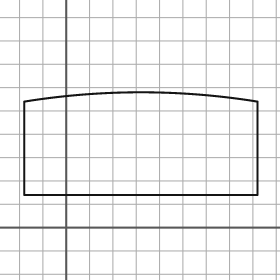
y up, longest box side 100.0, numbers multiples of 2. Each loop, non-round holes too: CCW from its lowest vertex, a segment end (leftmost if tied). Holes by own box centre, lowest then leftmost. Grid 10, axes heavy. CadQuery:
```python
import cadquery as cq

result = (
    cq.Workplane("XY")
    .moveTo(-18.0, 14.0)
    .lineTo(82.0, 14.0)
    .lineTo(82.0, 54.0)
    .threePointArc((32.0, 58.0), (-18.0, 54.0))
    .close()
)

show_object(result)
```